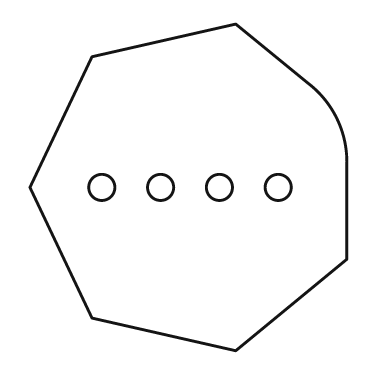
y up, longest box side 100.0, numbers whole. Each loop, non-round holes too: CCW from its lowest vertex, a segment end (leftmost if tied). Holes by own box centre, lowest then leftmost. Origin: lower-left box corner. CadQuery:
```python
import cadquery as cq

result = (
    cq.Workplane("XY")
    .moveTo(63.0, 0.0)
    .lineTo(97.0, 28.0)
    .lineTo(97.0, 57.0)
    .threePointArc((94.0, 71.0), (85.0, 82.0))
    .lineTo(63.0, 100.0)
    .lineTo(19.0, 90.0)
    .lineTo(0.0, 50.0)
    .lineTo(19.0, 10.0)
    .close()
    .moveTo(22.0, 50.0)
    .circle(4.0)
    .moveTo(40.0, 50.0)
    .circle(4.0)
    .moveTo(58.0, 50.0)
    .circle(4.0)
    .moveTo(76.0, 50.0)
    .circle(4.0)
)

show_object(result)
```